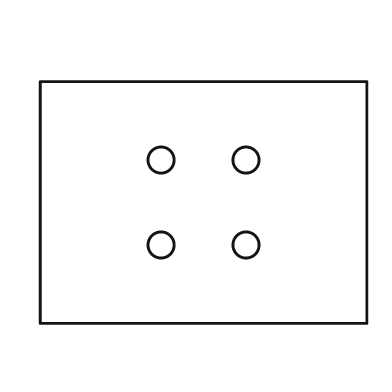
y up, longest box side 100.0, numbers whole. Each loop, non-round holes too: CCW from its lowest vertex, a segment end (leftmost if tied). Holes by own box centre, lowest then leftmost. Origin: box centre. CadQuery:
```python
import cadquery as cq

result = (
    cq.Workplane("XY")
    .moveTo(-50.0, -37.0)
    .lineTo(50.0, -37.0)
    .lineTo(50.0, 37.0)
    .lineTo(-50.0, 37.0)
    .close()
    .moveTo(-13.0, -13.0)
    .circle(4.0)
    .moveTo(13.0, -13.0)
    .circle(4.0)
    .moveTo(-13.0, 13.0)
    .circle(4.0)
    .moveTo(13.0, 13.0)
    .circle(4.0)
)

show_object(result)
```